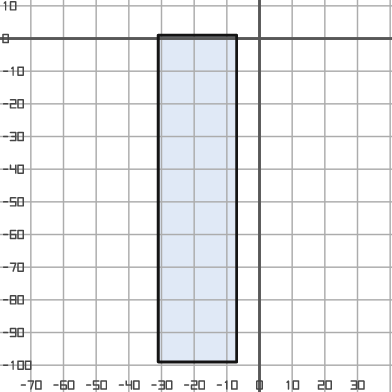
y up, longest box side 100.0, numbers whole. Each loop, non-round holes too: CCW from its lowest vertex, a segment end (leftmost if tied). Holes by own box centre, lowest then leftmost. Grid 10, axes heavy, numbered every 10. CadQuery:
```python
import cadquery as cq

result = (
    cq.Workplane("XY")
    .moveTo(-31.0, -99.0)
    .lineTo(-7.0, -99.0)
    .lineTo(-7.0, 1.0)
    .lineTo(-31.0, 1.0)
    .close()
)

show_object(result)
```